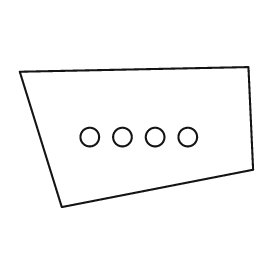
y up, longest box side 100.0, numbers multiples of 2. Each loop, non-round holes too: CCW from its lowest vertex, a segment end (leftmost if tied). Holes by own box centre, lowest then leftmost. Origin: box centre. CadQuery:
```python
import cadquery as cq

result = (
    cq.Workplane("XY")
    .moveTo(-32.0, -30.0)
    .lineTo(50.0, -14.0)
    .lineTo(48.0, 30.0)
    .lineTo(-50.0, 28.0)
    .close()
    .moveTo(-20.0, 0.0)
    .circle(4.0)
    .moveTo(-6.0, 0.0)
    .circle(4.0)
    .moveTo(8.0, 0.0)
    .circle(4.0)
    .moveTo(22.0, 0.0)
    .circle(4.0)
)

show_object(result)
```